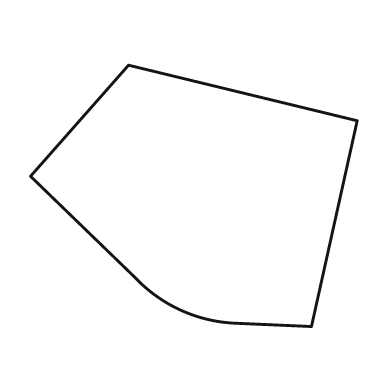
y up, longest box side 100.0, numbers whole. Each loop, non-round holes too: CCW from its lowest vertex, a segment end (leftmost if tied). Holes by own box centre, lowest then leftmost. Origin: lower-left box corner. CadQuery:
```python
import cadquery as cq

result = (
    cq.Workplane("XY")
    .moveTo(86.0, 0.0)
    .lineTo(100.0, 63.0)
    .lineTo(30.0, 80.0)
    .lineTo(0.0, 46.0)
    .lineTo(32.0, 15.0)
    .threePointArc((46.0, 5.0), (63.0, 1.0))
    .close()
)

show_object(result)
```